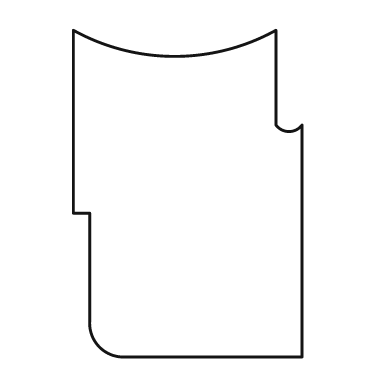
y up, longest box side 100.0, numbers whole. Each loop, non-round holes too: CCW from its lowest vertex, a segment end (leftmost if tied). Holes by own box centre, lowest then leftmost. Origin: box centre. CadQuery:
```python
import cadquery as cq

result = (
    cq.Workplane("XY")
    .moveTo(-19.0, -50.0)
    .lineTo(35.0, -50.0)
    .lineTo(35.0, 21.0)
    .threePointArc((31.0, 19.0), (27.0, 21.0))
    .lineTo(27.0, 50.0)
    .threePointArc((-4.0, 42.0), (-35.0, 50.0))
    .lineTo(-35.0, -6.0)
    .lineTo(-30.0, -6.0)
    .lineTo(-30.0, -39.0)
    .threePointArc((-27.0, -47.0), (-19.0, -50.0))
    .close()
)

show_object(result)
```